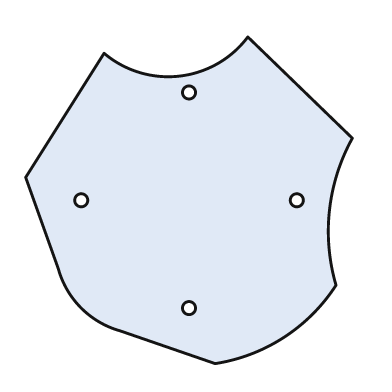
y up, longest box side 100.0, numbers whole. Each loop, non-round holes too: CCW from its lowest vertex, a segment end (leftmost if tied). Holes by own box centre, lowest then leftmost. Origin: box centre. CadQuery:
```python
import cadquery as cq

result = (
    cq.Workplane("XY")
    .moveTo(8.0, -50.0)
    .threePointArc((29.0, -42.0), (45.0, -26.0))
    .threePointArc((43.0, -3.0), (50.0, 19.0))
    .lineTo(18.0, 50.0)
    .threePointArc((-3.0, 38.0), (-26.0, 45.0))
    .lineTo(-50.0, 7.0)
    .lineTo(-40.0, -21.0)
    .threePointArc((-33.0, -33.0), (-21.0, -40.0))
    .close()
    .moveTo(0.0, -33.0)
    .circle(2.0)
    .moveTo(-33.0, 0.0)
    .circle(2.0)
    .moveTo(33.0, 0.0)
    .circle(2.0)
    .moveTo(0.0, 33.0)
    .circle(2.0)
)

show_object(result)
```